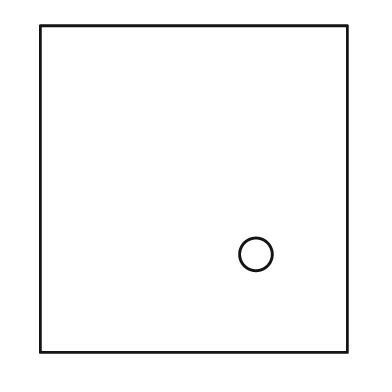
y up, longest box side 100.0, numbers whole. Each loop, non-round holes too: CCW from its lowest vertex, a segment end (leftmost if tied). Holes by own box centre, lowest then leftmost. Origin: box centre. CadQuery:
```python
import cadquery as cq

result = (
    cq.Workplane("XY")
    .moveTo(-47.0, -50.0)
    .lineTo(47.0, -50.0)
    .lineTo(47.0, 50.0)
    .lineTo(-47.0, 50.0)
    .close()
    .moveTo(19.0, -20.0)
    .circle(5.0)
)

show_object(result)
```